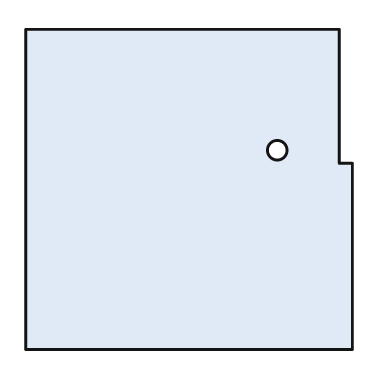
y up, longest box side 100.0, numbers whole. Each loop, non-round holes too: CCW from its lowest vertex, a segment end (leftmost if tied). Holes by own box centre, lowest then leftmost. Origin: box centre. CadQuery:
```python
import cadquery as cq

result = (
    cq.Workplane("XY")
    .moveTo(-50.0, -49.0)
    .lineTo(50.0, -49.0)
    .lineTo(50.0, 8.0)
    .lineTo(46.0, 8.0)
    .lineTo(46.0, 49.0)
    .lineTo(-50.0, 49.0)
    .close()
    .moveTo(27.0, 12.0)
    .circle(3.0)
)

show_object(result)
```